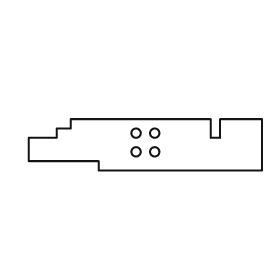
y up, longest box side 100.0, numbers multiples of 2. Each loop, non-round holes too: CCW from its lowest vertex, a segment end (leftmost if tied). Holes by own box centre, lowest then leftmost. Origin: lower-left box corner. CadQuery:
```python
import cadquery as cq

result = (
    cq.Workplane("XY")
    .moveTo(30.0, 0.0)
    .lineTo(100.0, 0.0)
    .lineTo(100.0, 22.0)
    .lineTo(82.0, 22.0)
    .lineTo(82.0, 14.0)
    .lineTo(78.0, 14.0)
    .lineTo(78.0, 22.0)
    .lineTo(18.0, 22.0)
    .lineTo(18.0, 18.0)
    .lineTo(12.0, 18.0)
    .lineTo(12.0, 14.0)
    .lineTo(0.0, 14.0)
    .lineTo(0.0, 4.0)
    .lineTo(30.0, 4.0)
    .close()
    .moveTo(46.0, 8.0)
    .circle(2.0)
    .moveTo(54.0, 8.0)
    .circle(2.0)
    .moveTo(46.0, 16.0)
    .circle(2.0)
    .moveTo(54.0, 16.0)
    .circle(2.0)
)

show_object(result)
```